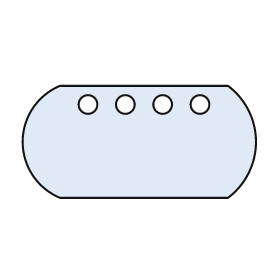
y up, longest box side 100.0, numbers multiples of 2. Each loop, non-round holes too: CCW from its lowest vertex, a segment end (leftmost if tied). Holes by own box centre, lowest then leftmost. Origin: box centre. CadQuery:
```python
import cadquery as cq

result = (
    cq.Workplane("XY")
    .moveTo(-34.0, -24.0)
    .lineTo(38.0, -24.0)
    .threePointArc((50.0, 0.0), (38.0, 24.0))
    .lineTo(-34.0, 24.0)
    .threePointArc((-50.0, 0.0), (-34.0, -24.0))
    .close()
    .moveTo(-22.0, 16.0)
    .circle(4.0)
    .moveTo(-6.0, 16.0)
    .circle(4.0)
    .moveTo(10.0, 16.0)
    .circle(4.0)
    .moveTo(26.0, 16.0)
    .circle(4.0)
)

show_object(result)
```